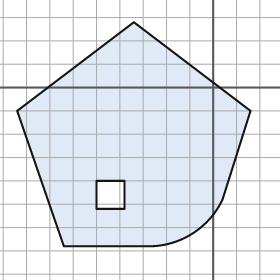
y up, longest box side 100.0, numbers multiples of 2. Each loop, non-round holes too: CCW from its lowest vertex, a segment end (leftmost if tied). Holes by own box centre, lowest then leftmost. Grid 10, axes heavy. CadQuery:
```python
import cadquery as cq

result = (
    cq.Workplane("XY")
    .moveTo(-64.0, -68.0)
    .lineTo(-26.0, -68.0)
    .threePointArc((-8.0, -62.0), (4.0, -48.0))
    .lineTo(16.0, -10.0)
    .lineTo(-34.0, 28.0)
    .lineTo(-84.0, -10.0)
    .close()
    .moveTo(-50.0, -52.0)
    .lineTo(-38.0, -52.0)
    .lineTo(-38.0, -40.0)
    .lineTo(-50.0, -40.0)
    .close()
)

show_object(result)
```